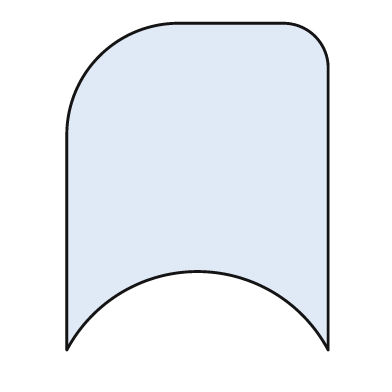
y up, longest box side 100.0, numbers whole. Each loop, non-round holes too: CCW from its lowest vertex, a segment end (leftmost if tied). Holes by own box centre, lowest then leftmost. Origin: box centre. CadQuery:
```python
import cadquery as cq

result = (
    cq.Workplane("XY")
    .moveTo(-40.0, -50.0)
    .threePointArc((0.0, -26.0), (40.0, -50.0))
    .lineTo(40.0, 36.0)
    .threePointArc((36.0, 46.0), (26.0, 50.0))
    .lineTo(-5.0, 50.0)
    .threePointArc((-30.0, 40.0), (-40.0, 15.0))
    .close()
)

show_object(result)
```